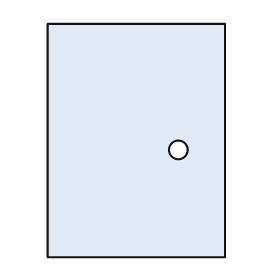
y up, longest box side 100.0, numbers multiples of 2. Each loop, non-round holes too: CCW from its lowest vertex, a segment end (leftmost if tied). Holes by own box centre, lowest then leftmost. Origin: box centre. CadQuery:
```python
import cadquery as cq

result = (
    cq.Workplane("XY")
    .moveTo(-38.0, -50.0)
    .lineTo(38.0, -50.0)
    .lineTo(38.0, 50.0)
    .lineTo(-38.0, 50.0)
    .close()
    .moveTo(18.0, -4.0)
    .circle(4.0)
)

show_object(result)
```